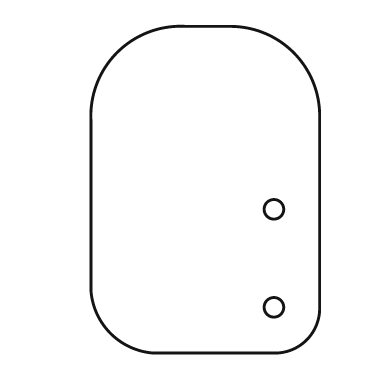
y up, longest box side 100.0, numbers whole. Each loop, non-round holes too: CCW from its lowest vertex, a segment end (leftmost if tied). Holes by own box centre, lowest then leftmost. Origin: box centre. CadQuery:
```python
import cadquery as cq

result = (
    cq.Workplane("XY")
    .moveTo(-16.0, -50.0)
    .lineTo(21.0, -50.0)
    .threePointArc((31.0, -46.0), (35.0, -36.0))
    .lineTo(35.0, 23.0)
    .threePointArc((27.0, 42.0), (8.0, 50.0))
    .lineTo(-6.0, 50.0)
    .threePointArc((-27.0, 42.0), (-35.0, 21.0))
    .lineTo(-35.0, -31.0)
    .threePointArc((-29.0, -44.0), (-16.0, -50.0))
    .close()
    .moveTo(21.0, -36.0)
    .circle(3.0)
    .moveTo(21.0, -6.0)
    .circle(3.0)
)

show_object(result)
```